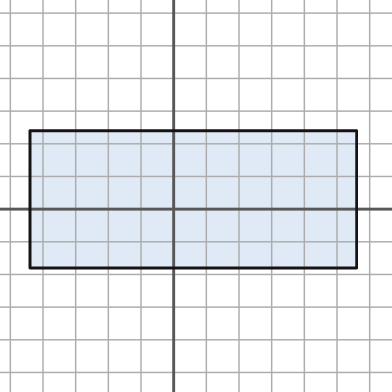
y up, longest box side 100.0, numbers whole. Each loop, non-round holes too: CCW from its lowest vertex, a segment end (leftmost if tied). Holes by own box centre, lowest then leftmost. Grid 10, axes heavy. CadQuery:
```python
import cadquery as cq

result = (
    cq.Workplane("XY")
    .moveTo(-44.0, -18.0)
    .lineTo(56.0, -18.0)
    .lineTo(56.0, 24.0)
    .lineTo(-44.0, 24.0)
    .close()
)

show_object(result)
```